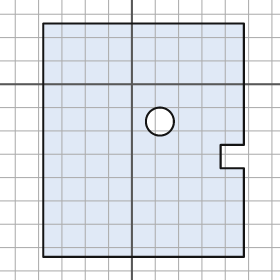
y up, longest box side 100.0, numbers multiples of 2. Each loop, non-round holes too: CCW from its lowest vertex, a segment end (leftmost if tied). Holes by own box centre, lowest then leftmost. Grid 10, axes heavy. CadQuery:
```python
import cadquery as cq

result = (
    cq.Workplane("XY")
    .moveTo(-38.0, -74.0)
    .lineTo(48.0, -74.0)
    .lineTo(48.0, -36.0)
    .lineTo(38.0, -36.0)
    .lineTo(38.0, -26.0)
    .lineTo(48.0, -26.0)
    .lineTo(48.0, 26.0)
    .lineTo(-38.0, 26.0)
    .close()
    .moveTo(12.0, -16.0)
    .circle(6.0)
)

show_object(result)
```